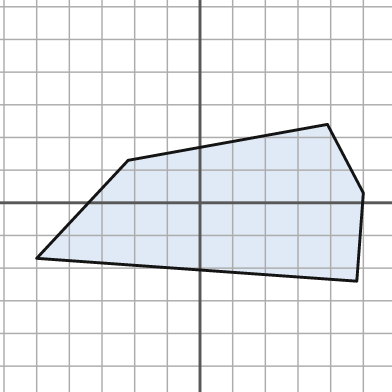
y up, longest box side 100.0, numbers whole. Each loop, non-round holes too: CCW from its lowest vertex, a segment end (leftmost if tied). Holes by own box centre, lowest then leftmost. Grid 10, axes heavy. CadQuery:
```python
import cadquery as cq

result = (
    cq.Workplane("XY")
    .moveTo(48.0, -24.0)
    .lineTo(50.0, 3.0)
    .lineTo(39.0, 24.0)
    .lineTo(-22.0, 13.0)
    .lineTo(-50.0, -17.0)
    .close()
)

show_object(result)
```